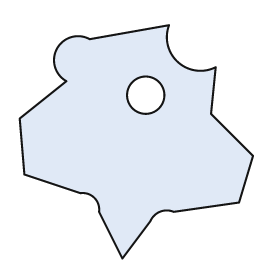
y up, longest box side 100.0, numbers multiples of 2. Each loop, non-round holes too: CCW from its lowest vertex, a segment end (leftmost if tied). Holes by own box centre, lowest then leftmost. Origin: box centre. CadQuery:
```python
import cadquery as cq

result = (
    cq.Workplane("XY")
    .moveTo(-6.0, -50.0)
    .lineTo(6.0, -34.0)
    .threePointArc((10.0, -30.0), (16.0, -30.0))
    .lineTo(44.0, -26.0)
    .lineTo(50.0, -6.0)
    .lineTo(32.0, 12.0)
    .lineTo(34.0, 32.0)
    .threePointArc((18.0, 34.0), (14.0, 50.0))
    .lineTo(-20.0, 44.0)
    .threePointArc((-34.0, 40.0), (-30.0, 26.0))
    .lineTo(-50.0, 10.0)
    .lineTo(-48.0, -14.0)
    .lineTo(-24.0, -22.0)
    .threePointArc((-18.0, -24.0), (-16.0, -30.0))
    .close()
    .moveTo(4.0, 20.0)
    .circle(8.0)
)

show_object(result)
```